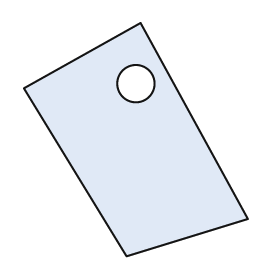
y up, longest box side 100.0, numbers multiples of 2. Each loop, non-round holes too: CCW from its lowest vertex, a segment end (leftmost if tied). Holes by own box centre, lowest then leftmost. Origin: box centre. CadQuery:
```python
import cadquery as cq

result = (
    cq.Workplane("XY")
    .moveTo(-4.0, -50.0)
    .lineTo(48.0, -34.0)
    .lineTo(2.0, 50.0)
    .lineTo(-48.0, 22.0)
    .close()
    .moveTo(0.0, 24.0)
    .circle(8.0)
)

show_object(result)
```